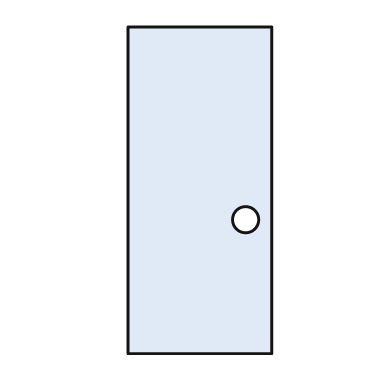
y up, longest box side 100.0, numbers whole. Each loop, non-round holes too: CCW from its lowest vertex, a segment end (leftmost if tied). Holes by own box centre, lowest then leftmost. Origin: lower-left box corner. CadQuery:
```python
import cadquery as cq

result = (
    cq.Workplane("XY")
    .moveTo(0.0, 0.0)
    .lineTo(44.0, 0.0)
    .lineTo(44.0, 100.0)
    .lineTo(0.0, 100.0)
    .close()
    .moveTo(36.0, 41.0)
    .circle(4.0)
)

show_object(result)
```